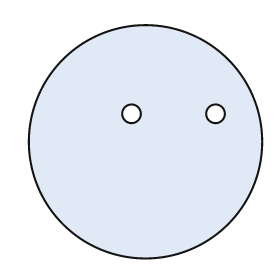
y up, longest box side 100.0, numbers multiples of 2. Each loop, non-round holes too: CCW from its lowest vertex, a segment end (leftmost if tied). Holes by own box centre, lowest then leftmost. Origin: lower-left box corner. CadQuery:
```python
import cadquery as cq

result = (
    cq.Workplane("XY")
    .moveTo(50.0, 50.0)
    .circle(50.0)
    .moveTo(44.0, 62.0)
    .circle(4.0)
    .moveTo(80.0, 62.0)
    .circle(4.0)
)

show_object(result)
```